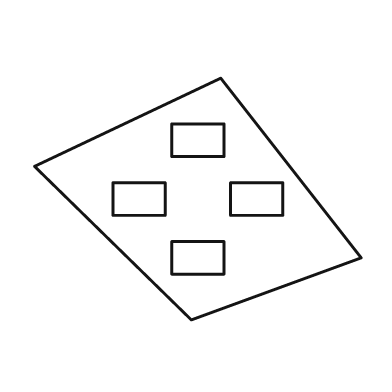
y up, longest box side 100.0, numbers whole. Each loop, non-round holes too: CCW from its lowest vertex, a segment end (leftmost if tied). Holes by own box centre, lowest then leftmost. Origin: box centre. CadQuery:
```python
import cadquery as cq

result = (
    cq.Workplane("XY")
    .moveTo(-2.0, -37.0)
    .lineTo(50.0, -18.0)
    .lineTo(7.0, 37.0)
    .lineTo(-50.0, 10.0)
    .close()
    .moveTo(-8.0, -23.0)
    .lineTo(8.0, -23.0)
    .lineTo(8.0, -13.0)
    .lineTo(-8.0, -13.0)
    .close()
    .moveTo(-26.0, -5.0)
    .lineTo(-10.0, -5.0)
    .lineTo(-10.0, 5.0)
    .lineTo(-26.0, 5.0)
    .close()
    .moveTo(10.0, -5.0)
    .lineTo(26.0, -5.0)
    .lineTo(26.0, 5.0)
    .lineTo(10.0, 5.0)
    .close()
    .moveTo(-8.0, 13.0)
    .lineTo(8.0, 13.0)
    .lineTo(8.0, 23.0)
    .lineTo(-8.0, 23.0)
    .close()
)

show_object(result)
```